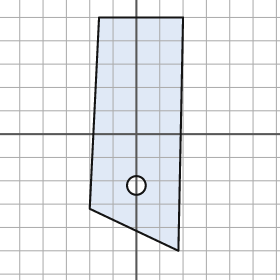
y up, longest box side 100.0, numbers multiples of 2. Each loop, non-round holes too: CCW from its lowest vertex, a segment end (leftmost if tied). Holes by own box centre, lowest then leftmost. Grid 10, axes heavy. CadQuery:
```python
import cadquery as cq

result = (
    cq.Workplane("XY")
    .moveTo(18.0, -50.0)
    .lineTo(20.0, 50.0)
    .lineTo(-16.0, 50.0)
    .lineTo(-20.0, -32.0)
    .close()
    .moveTo(0.0, -22.0)
    .circle(4.0)
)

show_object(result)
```